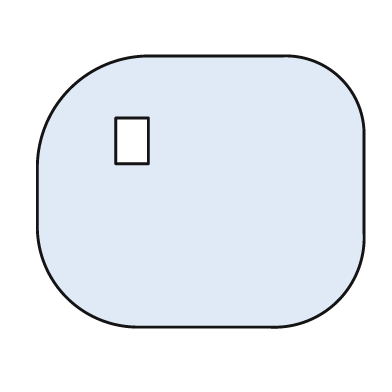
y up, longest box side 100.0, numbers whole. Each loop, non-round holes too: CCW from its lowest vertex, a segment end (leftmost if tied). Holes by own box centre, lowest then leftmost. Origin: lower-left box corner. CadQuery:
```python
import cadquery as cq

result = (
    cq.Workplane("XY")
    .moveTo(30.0, 0.0)
    .lineTo(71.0, 0.0)
    .threePointArc((92.0, 8.0), (100.0, 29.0))
    .lineTo(100.0, 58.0)
    .threePointArc((93.0, 76.0), (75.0, 83.0))
    .lineTo(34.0, 83.0)
    .threePointArc((10.0, 73.0), (0.0, 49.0))
    .lineTo(0.0, 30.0)
    .threePointArc((9.0, 9.0), (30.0, 0.0))
    .close()
    .moveTo(24.0, 50.0)
    .lineTo(34.0, 50.0)
    .lineTo(34.0, 64.0)
    .lineTo(24.0, 64.0)
    .close()
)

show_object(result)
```